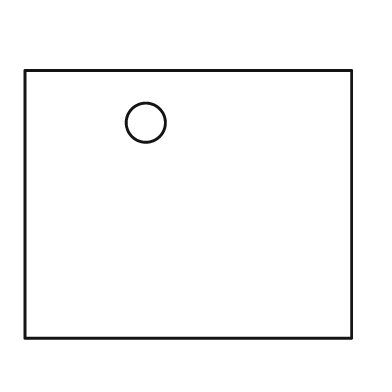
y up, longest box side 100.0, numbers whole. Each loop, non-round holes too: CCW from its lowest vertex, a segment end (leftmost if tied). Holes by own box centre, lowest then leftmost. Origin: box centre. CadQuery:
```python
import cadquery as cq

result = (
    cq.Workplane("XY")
    .moveTo(-50.0, -41.0)
    .lineTo(50.0, -41.0)
    .lineTo(50.0, 41.0)
    .lineTo(-50.0, 41.0)
    .close()
    .moveTo(-13.0, 25.0)
    .circle(6.0)
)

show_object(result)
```